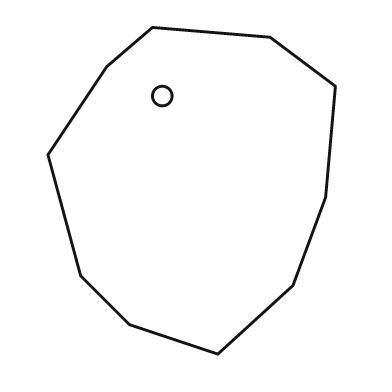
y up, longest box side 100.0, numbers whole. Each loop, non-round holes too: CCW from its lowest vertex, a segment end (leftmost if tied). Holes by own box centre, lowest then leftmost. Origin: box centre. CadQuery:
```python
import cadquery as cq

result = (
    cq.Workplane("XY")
    .moveTo(8.0, -50.0)
    .lineTo(31.0, -29.0)
    .lineTo(41.0, -2.0)
    .lineTo(44.0, 32.0)
    .lineTo(24.0, 47.0)
    .lineTo(-12.0, 50.0)
    .lineTo(-26.0, 38.0)
    .lineTo(-44.0, 11.0)
    .lineTo(-34.0, -26.0)
    .lineTo(-19.0, -41.0)
    .close()
    .moveTo(-9.0, 29.0)
    .circle(3.0)
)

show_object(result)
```